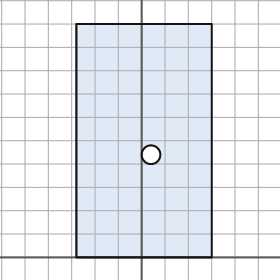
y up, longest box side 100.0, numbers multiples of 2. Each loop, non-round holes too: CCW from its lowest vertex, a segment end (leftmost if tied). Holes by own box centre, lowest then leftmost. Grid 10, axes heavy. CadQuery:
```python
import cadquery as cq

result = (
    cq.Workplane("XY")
    .moveTo(-28.0, 0.0)
    .lineTo(30.0, 0.0)
    .lineTo(30.0, 100.0)
    .lineTo(-28.0, 100.0)
    .close()
    .moveTo(4.0, 44.0)
    .circle(4.0)
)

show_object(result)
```